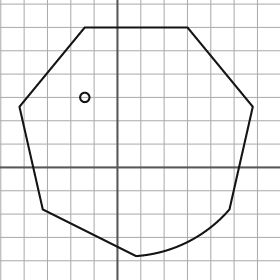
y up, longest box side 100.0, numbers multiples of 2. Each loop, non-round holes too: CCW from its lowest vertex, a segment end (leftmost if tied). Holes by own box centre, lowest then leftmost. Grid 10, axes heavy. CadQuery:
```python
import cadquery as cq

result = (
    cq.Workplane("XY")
    .moveTo(8.0, -38.0)
    .threePointArc((30.0, -32.0), (48.0, -18.0))
    .lineTo(58.0, 26.0)
    .lineTo(30.0, 60.0)
    .lineTo(-14.0, 60.0)
    .lineTo(-42.0, 26.0)
    .lineTo(-32.0, -18.0)
    .close()
    .moveTo(-14.0, 30.0)
    .circle(2.0)
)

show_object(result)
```